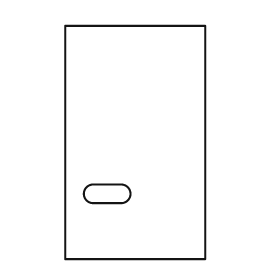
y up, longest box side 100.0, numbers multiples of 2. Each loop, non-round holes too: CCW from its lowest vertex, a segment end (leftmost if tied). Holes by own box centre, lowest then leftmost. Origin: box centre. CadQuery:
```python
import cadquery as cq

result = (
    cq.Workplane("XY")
    .moveTo(-30.0, -50.0)
    .lineTo(30.0, -50.0)
    .lineTo(30.0, 50.0)
    .lineTo(-30.0, 50.0)
    .close()
    .moveTo(-18.0, -26.0)
    .lineTo(-6.0, -26.0)
    .threePointArc((-2.0, -22.0), (-6.0, -18.0))
    .lineTo(-18.0, -18.0)
    .threePointArc((-22.0, -22.0), (-18.0, -26.0))
    .close()
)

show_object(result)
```